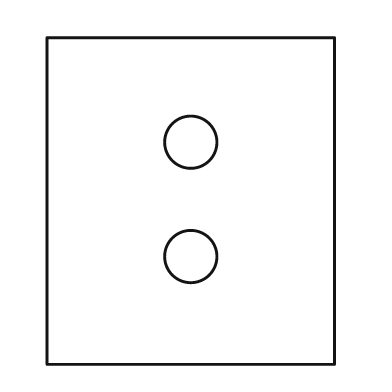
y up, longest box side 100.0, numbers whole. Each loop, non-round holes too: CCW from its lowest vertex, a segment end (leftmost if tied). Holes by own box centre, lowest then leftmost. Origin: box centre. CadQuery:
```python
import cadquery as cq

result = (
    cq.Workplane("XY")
    .moveTo(-44.0, -50.0)
    .lineTo(44.0, -50.0)
    .lineTo(44.0, 50.0)
    .lineTo(-44.0, 50.0)
    .close()
    .moveTo(0.0, -17.0)
    .circle(8.0)
    .moveTo(0.0, 18.0)
    .circle(8.0)
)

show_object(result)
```